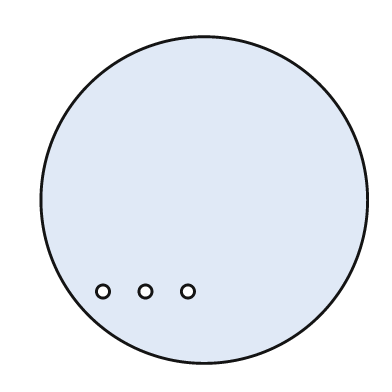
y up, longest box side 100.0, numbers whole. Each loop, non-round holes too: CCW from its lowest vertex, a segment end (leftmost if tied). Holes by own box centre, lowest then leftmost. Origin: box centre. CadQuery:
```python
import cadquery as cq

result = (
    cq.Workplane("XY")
    .moveTo(0.0, 0.0)
    .circle(50.0)
    .moveTo(-31.0, -28.0)
    .circle(2.0)
    .moveTo(-18.0, -28.0)
    .circle(2.0)
    .moveTo(-5.0, -28.0)
    .circle(2.0)
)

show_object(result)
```